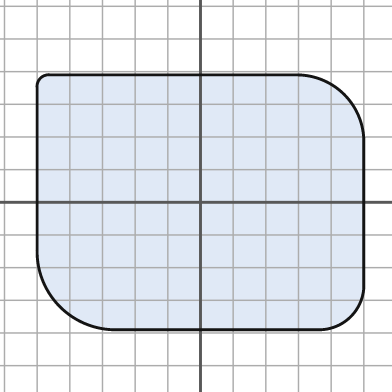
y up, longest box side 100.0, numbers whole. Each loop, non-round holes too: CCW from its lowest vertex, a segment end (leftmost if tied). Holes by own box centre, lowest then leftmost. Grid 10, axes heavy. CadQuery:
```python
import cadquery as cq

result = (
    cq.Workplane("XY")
    .moveTo(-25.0, -39.0)
    .lineTo(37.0, -39.0)
    .threePointArc((46.0, -35.0), (50.0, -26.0))
    .lineTo(50.0, 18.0)
    .threePointArc((44.0, 33.0), (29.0, 39.0))
    .lineTo(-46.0, 39.0)
    .threePointArc((-49.0, 38.0), (-50.0, 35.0))
    .lineTo(-50.0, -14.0)
    .threePointArc((-43.0, -32.0), (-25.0, -39.0))
    .close()
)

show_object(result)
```